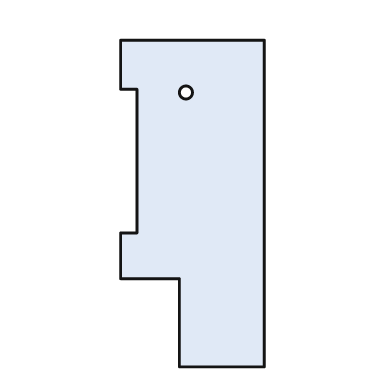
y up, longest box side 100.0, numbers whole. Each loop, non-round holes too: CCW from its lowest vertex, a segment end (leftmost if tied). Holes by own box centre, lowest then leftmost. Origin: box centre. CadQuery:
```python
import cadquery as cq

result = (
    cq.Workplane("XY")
    .moveTo(-4.0, -50.0)
    .lineTo(22.0, -50.0)
    .lineTo(22.0, 50.0)
    .lineTo(-22.0, 50.0)
    .lineTo(-22.0, 35.0)
    .lineTo(-17.0, 35.0)
    .lineTo(-17.0, -9.0)
    .lineTo(-22.0, -9.0)
    .lineTo(-22.0, -23.0)
    .lineTo(-4.0, -23.0)
    .close()
    .moveTo(-2.0, 34.0)
    .circle(2.0)
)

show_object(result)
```